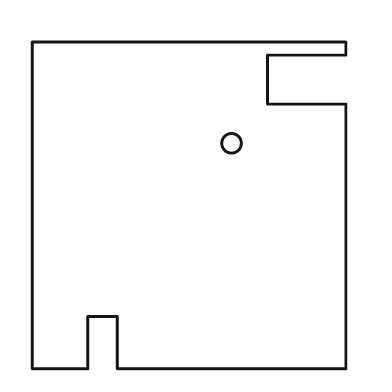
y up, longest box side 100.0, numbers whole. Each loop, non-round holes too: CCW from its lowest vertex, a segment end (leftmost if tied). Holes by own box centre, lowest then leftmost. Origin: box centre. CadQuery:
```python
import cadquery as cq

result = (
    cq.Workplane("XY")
    .moveTo(-48.0, -50.0)
    .lineTo(-31.0, -50.0)
    .lineTo(-31.0, -34.0)
    .lineTo(-22.0, -34.0)
    .lineTo(-22.0, -50.0)
    .lineTo(48.0, -50.0)
    .lineTo(48.0, 31.0)
    .lineTo(24.0, 31.0)
    .lineTo(24.0, 46.0)
    .lineTo(48.0, 46.0)
    .lineTo(48.0, 50.0)
    .lineTo(-48.0, 50.0)
    .close()
    .moveTo(13.0, 19.0)
    .circle(3.0)
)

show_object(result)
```